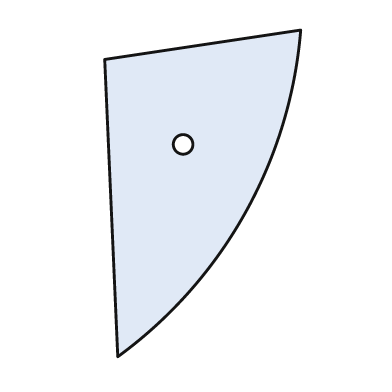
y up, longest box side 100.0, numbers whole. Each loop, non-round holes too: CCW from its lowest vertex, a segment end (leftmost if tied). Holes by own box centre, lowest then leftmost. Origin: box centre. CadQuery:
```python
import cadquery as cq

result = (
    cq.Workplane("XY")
    .moveTo(-26.0, -50.0)
    .threePointArc((13.0, -6.0), (30.0, 50.0))
    .lineTo(-30.0, 41.0)
    .close()
    .moveTo(-6.0, 15.0)
    .circle(3.0)
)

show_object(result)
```